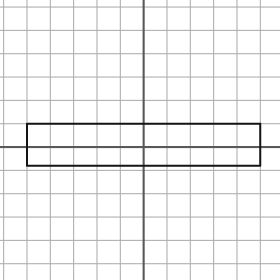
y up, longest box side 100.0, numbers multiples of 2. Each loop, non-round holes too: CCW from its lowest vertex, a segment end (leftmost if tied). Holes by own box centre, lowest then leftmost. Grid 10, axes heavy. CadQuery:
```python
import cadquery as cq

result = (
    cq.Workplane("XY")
    .moveTo(-50.0, -8.0)
    .lineTo(50.0, -8.0)
    .lineTo(50.0, 10.0)
    .lineTo(-50.0, 10.0)
    .close()
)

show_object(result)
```